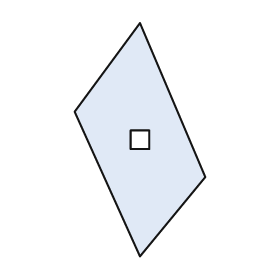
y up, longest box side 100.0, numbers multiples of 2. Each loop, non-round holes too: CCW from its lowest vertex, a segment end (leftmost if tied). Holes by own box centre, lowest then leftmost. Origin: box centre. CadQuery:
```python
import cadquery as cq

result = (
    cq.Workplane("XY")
    .moveTo(0.0, -50.0)
    .lineTo(28.0, -16.0)
    .lineTo(0.0, 50.0)
    .lineTo(-28.0, 12.0)
    .close()
    .moveTo(-4.0, -4.0)
    .lineTo(4.0, -4.0)
    .lineTo(4.0, 4.0)
    .lineTo(-4.0, 4.0)
    .close()
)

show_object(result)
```